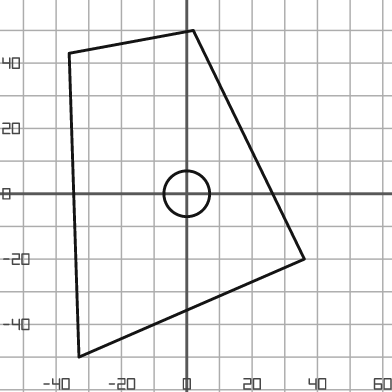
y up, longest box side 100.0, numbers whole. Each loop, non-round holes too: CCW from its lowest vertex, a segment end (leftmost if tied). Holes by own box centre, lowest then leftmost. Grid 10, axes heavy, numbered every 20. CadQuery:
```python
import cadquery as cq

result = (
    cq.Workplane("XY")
    .moveTo(-33.0, -50.0)
    .lineTo(36.0, -20.0)
    .lineTo(2.0, 50.0)
    .lineTo(-36.0, 43.0)
    .close()
    .moveTo(0.0, 0.0)
    .circle(7.0)
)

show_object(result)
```